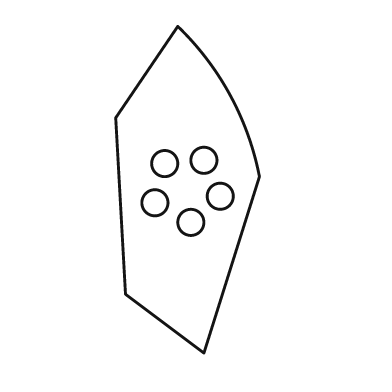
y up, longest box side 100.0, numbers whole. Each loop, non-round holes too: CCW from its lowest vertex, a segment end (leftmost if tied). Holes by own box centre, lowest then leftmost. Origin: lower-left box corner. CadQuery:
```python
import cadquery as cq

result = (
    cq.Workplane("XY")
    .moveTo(27.0, 0.0)
    .lineTo(44.0, 54.0)
    .threePointArc((35.0, 79.0), (19.0, 100.0))
    .lineTo(0.0, 72.0)
    .lineTo(3.0, 18.0)
    .close()
    .moveTo(23.0, 40.0)
    .circle(4.0)
    .moveTo(12.0, 46.0)
    .circle(4.0)
    .moveTo(32.0, 48.0)
    .circle(4.0)
    .moveTo(15.0, 58.0)
    .circle(4.0)
    .moveTo(27.0, 59.0)
    .circle(4.0)
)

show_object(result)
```